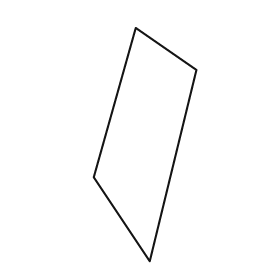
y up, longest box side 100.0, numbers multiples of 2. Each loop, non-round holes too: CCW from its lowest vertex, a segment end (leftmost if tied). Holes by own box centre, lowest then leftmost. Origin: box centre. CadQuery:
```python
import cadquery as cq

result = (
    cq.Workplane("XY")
    .moveTo(2.0, -50.0)
    .lineTo(22.0, 32.0)
    .lineTo(-4.0, 50.0)
    .lineTo(-22.0, -14.0)
    .close()
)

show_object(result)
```